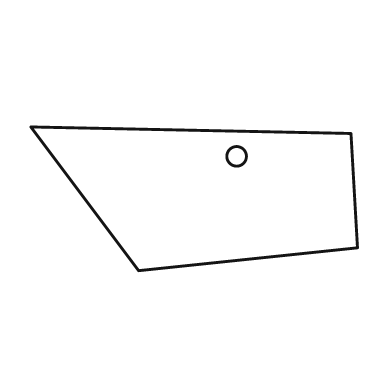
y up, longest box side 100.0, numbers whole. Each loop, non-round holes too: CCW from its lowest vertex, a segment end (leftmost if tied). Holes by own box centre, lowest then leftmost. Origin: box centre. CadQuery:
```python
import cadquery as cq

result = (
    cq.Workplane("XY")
    .moveTo(-17.0, -22.0)
    .lineTo(50.0, -15.0)
    .lineTo(48.0, 20.0)
    .lineTo(-50.0, 22.0)
    .close()
    .moveTo(13.0, 13.0)
    .circle(3.0)
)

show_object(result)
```